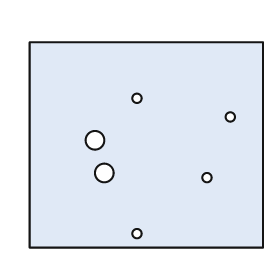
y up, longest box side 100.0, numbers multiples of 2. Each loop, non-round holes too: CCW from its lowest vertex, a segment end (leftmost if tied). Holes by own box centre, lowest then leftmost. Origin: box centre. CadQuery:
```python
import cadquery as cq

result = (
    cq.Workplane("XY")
    .moveTo(-50.0, -44.0)
    .lineTo(50.0, -44.0)
    .lineTo(50.0, 44.0)
    .lineTo(-50.0, 44.0)
    .close()
    .moveTo(-4.0, -38.0)
    .circle(2.0)
    .moveTo(26.0, -14.0)
    .circle(2.0)
    .moveTo(-18.0, -12.0)
    .circle(4.0)
    .moveTo(-22.0, 2.0)
    .circle(4.0)
    .moveTo(36.0, 12.0)
    .circle(2.0)
    .moveTo(-4.0, 20.0)
    .circle(2.0)
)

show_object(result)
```